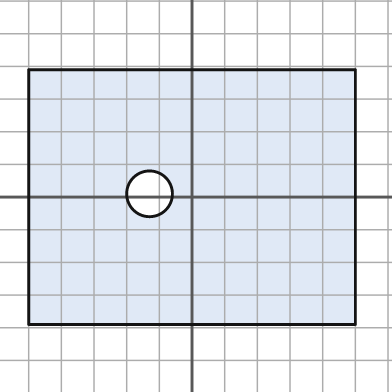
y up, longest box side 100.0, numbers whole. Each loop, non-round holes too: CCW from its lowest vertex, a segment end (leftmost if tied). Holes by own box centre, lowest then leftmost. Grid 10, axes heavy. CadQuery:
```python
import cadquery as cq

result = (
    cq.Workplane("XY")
    .moveTo(-50.0, -39.0)
    .lineTo(50.0, -39.0)
    .lineTo(50.0, 39.0)
    .lineTo(-50.0, 39.0)
    .close()
    .moveTo(-13.0, 1.0)
    .circle(7.0)
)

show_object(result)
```